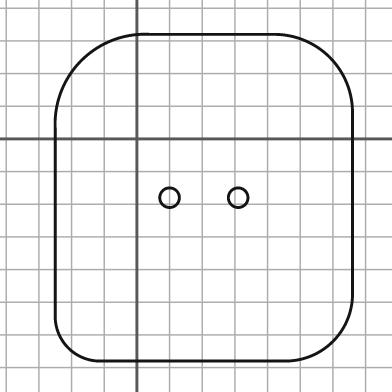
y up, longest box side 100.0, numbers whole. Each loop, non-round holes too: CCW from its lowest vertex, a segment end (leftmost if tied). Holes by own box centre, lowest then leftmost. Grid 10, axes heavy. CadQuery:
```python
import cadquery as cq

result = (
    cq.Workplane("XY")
    .moveTo(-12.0, -68.0)
    .lineTo(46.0, -68.0)
    .threePointArc((60.0, -62.0), (66.0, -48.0))
    .lineTo(66.0, 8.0)
    .threePointArc((59.0, 25.0), (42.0, 32.0))
    .lineTo(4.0, 32.0)
    .threePointArc((-17.0, 24.0), (-25.0, 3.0))
    .lineTo(-25.0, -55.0)
    .threePointArc((-21.0, -64.0), (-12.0, -68.0))
    .close()
    .moveTo(10.0, -18.0)
    .circle(3.0)
    .moveTo(31.0, -18.0)
    .circle(3.0)
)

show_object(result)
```